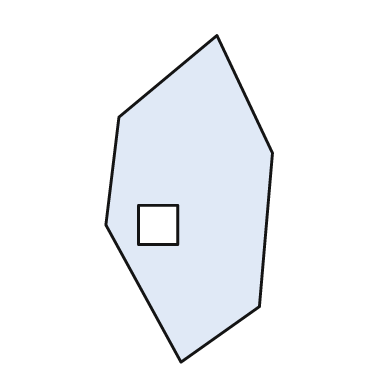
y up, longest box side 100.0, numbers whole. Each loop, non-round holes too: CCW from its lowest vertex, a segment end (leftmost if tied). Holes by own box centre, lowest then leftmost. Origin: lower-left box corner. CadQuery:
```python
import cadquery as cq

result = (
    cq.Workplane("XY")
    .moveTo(23.0, 0.0)
    .lineTo(47.0, 17.0)
    .lineTo(51.0, 64.0)
    .lineTo(34.0, 100.0)
    .lineTo(4.0, 75.0)
    .lineTo(0.0, 42.0)
    .close()
    .moveTo(10.0, 36.0)
    .lineTo(22.0, 36.0)
    .lineTo(22.0, 48.0)
    .lineTo(10.0, 48.0)
    .close()
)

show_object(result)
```